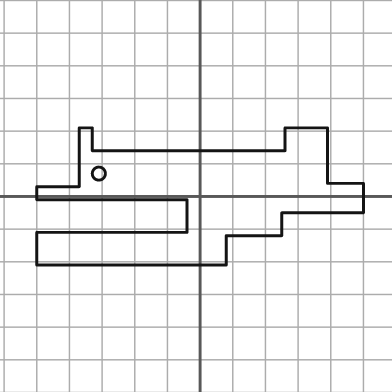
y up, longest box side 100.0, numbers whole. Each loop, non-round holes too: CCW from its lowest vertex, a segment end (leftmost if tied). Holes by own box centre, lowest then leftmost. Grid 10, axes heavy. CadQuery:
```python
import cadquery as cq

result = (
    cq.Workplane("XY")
    .moveTo(-50.0, -21.0)
    .lineTo(8.0, -21.0)
    .lineTo(8.0, -12.0)
    .lineTo(25.0, -12.0)
    .lineTo(25.0, -5.0)
    .lineTo(50.0, -5.0)
    .lineTo(50.0, 4.0)
    .lineTo(39.0, 4.0)
    .lineTo(39.0, 21.0)
    .lineTo(26.0, 21.0)
    .lineTo(26.0, 14.0)
    .lineTo(-33.0, 14.0)
    .lineTo(-33.0, 21.0)
    .lineTo(-37.0, 21.0)
    .lineTo(-37.0, 3.0)
    .lineTo(-50.0, 3.0)
    .lineTo(-50.0, -1.0)
    .lineTo(-4.0, -1.0)
    .lineTo(-4.0, -11.0)
    .lineTo(-50.0, -11.0)
    .close()
    .moveTo(-31.0, 7.0)
    .circle(2.0)
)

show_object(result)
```